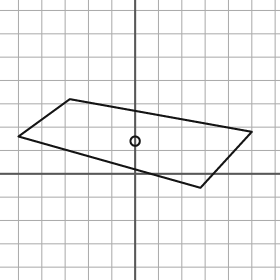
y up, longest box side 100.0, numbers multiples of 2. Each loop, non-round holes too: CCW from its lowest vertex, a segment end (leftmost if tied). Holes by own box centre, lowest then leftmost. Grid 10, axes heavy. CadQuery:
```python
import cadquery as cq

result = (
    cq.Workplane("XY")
    .moveTo(28.0, -6.0)
    .lineTo(50.0, 18.0)
    .lineTo(-28.0, 32.0)
    .lineTo(-50.0, 16.0)
    .close()
    .moveTo(0.0, 14.0)
    .circle(2.0)
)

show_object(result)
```